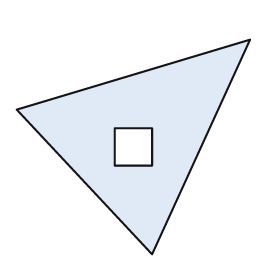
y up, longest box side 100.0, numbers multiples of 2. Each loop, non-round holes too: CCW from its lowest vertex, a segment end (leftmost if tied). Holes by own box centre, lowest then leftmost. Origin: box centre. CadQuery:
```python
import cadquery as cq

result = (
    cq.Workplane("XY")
    .moveTo(8.0, -46.0)
    .lineTo(50.0, 46.0)
    .lineTo(-50.0, 16.0)
    .close()
    .moveTo(-8.0, -8.0)
    .lineTo(8.0, -8.0)
    .lineTo(8.0, 8.0)
    .lineTo(-8.0, 8.0)
    .close()
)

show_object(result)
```